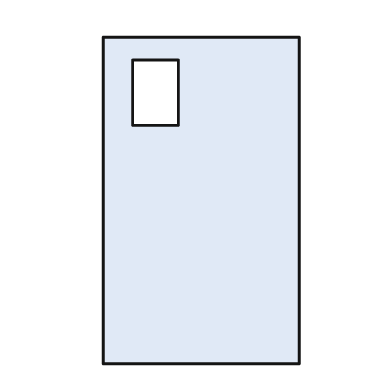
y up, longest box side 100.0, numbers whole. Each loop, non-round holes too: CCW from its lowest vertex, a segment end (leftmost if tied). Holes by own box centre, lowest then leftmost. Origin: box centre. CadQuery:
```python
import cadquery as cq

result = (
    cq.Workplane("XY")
    .moveTo(-30.0, -50.0)
    .lineTo(30.0, -50.0)
    .lineTo(30.0, 50.0)
    .lineTo(-30.0, 50.0)
    .close()
    .moveTo(-21.0, 23.0)
    .lineTo(-7.0, 23.0)
    .lineTo(-7.0, 43.0)
    .lineTo(-21.0, 43.0)
    .close()
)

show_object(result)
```